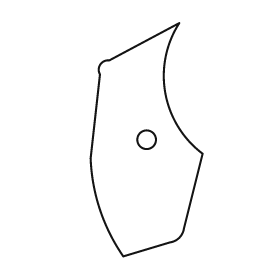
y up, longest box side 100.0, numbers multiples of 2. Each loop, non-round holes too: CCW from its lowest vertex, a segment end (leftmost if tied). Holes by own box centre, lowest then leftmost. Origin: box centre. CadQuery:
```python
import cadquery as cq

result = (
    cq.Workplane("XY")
    .moveTo(-10.0, -50.0)
    .lineTo(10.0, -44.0)
    .threePointArc((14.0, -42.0), (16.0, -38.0))
    .lineTo(24.0, -6.0)
    .threePointArc((8.0, 20.0), (14.0, 50.0))
    .lineTo(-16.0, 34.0)
    .threePointArc((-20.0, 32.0), (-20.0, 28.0))
    .lineTo(-24.0, -8.0)
    .threePointArc((-20.0, -30.0), (-10.0, -50.0))
    .close()
    .moveTo(0.0, 0.0)
    .circle(4.0)
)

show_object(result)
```